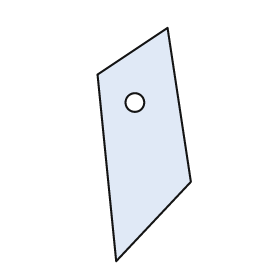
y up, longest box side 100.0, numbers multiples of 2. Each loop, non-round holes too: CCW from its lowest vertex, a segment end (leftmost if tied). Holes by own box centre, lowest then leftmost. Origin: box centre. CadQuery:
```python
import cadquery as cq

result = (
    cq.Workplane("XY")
    .moveTo(-12.0, -50.0)
    .lineTo(20.0, -16.0)
    .lineTo(10.0, 50.0)
    .lineTo(-20.0, 30.0)
    .close()
    .moveTo(-4.0, 18.0)
    .circle(4.0)
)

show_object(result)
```